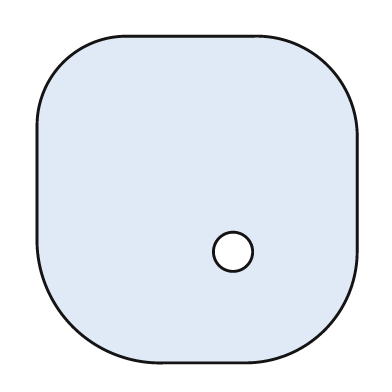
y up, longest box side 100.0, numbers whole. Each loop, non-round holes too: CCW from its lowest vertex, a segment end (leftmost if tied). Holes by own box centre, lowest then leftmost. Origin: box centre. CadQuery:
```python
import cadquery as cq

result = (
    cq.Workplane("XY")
    .moveTo(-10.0, -50.0)
    .lineTo(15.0, -50.0)
    .threePointArc((39.0, -40.0), (49.0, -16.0))
    .lineTo(49.0, 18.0)
    .threePointArc((40.0, 41.0), (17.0, 50.0))
    .lineTo(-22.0, 50.0)
    .threePointArc((-41.0, 42.0), (-49.0, 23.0))
    .lineTo(-49.0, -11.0)
    .threePointArc((-38.0, -39.0), (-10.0, -50.0))
    .close()
    .moveTo(11.0, -16.0)
    .circle(6.0)
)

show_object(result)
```